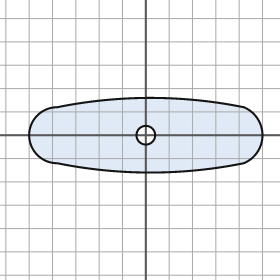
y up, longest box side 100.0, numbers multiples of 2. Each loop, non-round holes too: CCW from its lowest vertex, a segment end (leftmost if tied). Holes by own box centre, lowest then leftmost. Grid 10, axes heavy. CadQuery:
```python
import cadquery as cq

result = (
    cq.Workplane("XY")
    .moveTo(-38.0, -12.0)
    .threePointArc((2.0, -16.0), (42.0, -12.0))
    .threePointArc((50.0, 0.0), (42.0, 12.0))
    .threePointArc((2.0, 16.0), (-38.0, 12.0))
    .threePointArc((-50.0, 0.0), (-38.0, -12.0))
    .close()
    .moveTo(0.0, 0.0)
    .circle(4.0)
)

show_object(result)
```